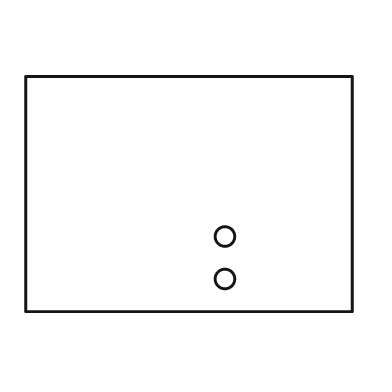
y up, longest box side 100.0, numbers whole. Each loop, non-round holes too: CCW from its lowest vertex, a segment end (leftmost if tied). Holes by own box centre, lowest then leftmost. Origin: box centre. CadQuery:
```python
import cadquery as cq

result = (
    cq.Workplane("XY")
    .moveTo(-50.0, -36.0)
    .lineTo(50.0, -36.0)
    .lineTo(50.0, 36.0)
    .lineTo(-50.0, 36.0)
    .close()
    .moveTo(11.0, -26.0)
    .circle(3.0)
    .moveTo(11.0, -13.0)
    .circle(3.0)
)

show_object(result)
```